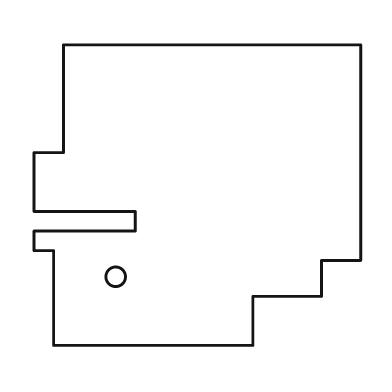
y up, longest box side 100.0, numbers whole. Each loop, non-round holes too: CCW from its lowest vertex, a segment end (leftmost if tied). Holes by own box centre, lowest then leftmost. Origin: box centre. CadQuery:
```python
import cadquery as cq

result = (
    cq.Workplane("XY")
    .moveTo(-44.0, -46.0)
    .lineTo(17.0, -46.0)
    .lineTo(17.0, -31.0)
    .lineTo(38.0, -31.0)
    .lineTo(38.0, -20.0)
    .lineTo(50.0, -20.0)
    .lineTo(50.0, 46.0)
    .lineTo(-41.0, 46.0)
    .lineTo(-41.0, 13.0)
    .lineTo(-50.0, 13.0)
    .lineTo(-50.0, -5.0)
    .lineTo(-19.0, -5.0)
    .lineTo(-19.0, -11.0)
    .lineTo(-50.0, -11.0)
    .lineTo(-50.0, -17.0)
    .lineTo(-44.0, -17.0)
    .close()
    .moveTo(-25.0, -25.0)
    .circle(3.0)
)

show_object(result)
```